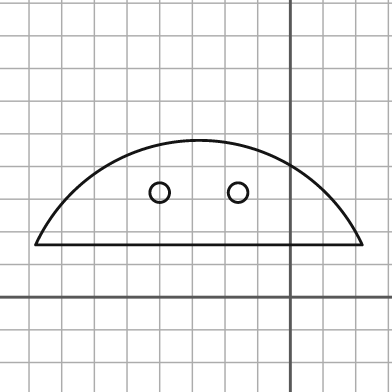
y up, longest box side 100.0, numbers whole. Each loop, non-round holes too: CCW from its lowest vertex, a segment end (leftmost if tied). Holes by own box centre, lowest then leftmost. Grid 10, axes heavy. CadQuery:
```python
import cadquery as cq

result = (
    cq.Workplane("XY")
    .moveTo(-78.0, 16.0)
    .lineTo(22.0, 16.0)
    .threePointArc((-28.0, 48.0), (-78.0, 16.0))
    .close()
    .moveTo(-40.0, 32.0)
    .circle(3.0)
    .moveTo(-16.0, 32.0)
    .circle(3.0)
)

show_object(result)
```